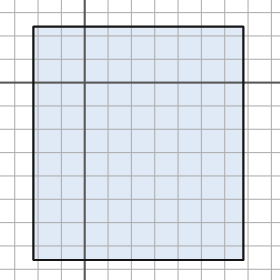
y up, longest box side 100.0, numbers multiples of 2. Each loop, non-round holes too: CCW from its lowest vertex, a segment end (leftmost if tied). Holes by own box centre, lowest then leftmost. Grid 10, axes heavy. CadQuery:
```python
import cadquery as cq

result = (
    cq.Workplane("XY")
    .moveTo(-22.0, -76.0)
    .lineTo(68.0, -76.0)
    .lineTo(68.0, 24.0)
    .lineTo(-22.0, 24.0)
    .close()
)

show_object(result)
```